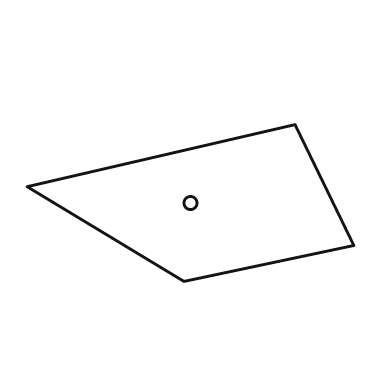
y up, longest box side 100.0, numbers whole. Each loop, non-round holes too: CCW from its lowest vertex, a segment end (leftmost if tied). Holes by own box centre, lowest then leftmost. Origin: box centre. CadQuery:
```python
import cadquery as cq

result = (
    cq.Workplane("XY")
    .moveTo(-2.0, -24.0)
    .lineTo(50.0, -13.0)
    .lineTo(32.0, 24.0)
    .lineTo(-50.0, 5.0)
    .close()
    .moveTo(0.0, 0.0)
    .circle(2.0)
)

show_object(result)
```